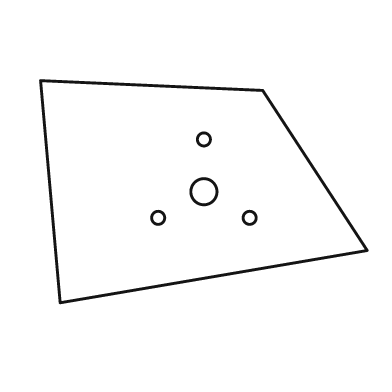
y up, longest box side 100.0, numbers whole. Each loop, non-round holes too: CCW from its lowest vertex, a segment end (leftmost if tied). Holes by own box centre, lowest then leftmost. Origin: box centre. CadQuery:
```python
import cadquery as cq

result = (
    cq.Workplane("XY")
    .moveTo(-44.0, -34.0)
    .lineTo(50.0, -18.0)
    .lineTo(18.0, 31.0)
    .lineTo(-50.0, 34.0)
    .close()
    .moveTo(-14.0, -8.0)
    .circle(2.0)
    .moveTo(14.0, -8.0)
    .circle(2.0)
    .moveTo(0.0, 0.0)
    .circle(4.0)
    .moveTo(0.0, 16.0)
    .circle(2.0)
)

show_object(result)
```